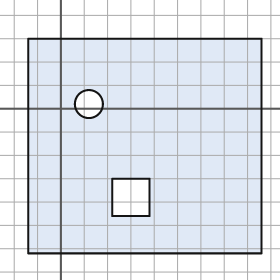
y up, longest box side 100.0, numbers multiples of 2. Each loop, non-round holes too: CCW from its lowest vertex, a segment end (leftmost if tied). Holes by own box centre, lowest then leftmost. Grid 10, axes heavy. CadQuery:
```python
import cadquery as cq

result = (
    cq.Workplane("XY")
    .moveTo(-14.0, -62.0)
    .lineTo(86.0, -62.0)
    .lineTo(86.0, 30.0)
    .lineTo(-14.0, 30.0)
    .close()
    .moveTo(22.0, -46.0)
    .lineTo(38.0, -46.0)
    .lineTo(38.0, -30.0)
    .lineTo(22.0, -30.0)
    .close()
    .moveTo(12.0, 2.0)
    .circle(6.0)
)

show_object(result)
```